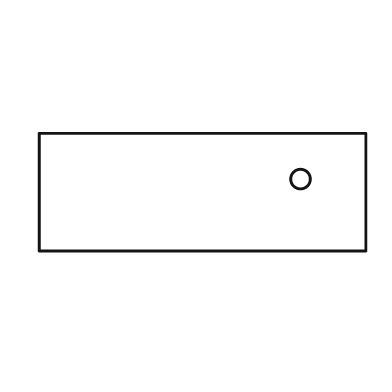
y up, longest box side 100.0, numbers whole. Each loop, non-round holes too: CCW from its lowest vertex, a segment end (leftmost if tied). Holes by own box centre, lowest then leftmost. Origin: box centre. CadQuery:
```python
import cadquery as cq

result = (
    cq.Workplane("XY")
    .moveTo(-50.0, -18.0)
    .lineTo(50.0, -18.0)
    .lineTo(50.0, 18.0)
    .lineTo(-50.0, 18.0)
    .close()
    .moveTo(30.0, 4.0)
    .circle(3.0)
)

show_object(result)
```